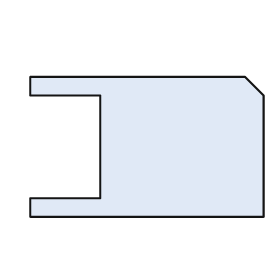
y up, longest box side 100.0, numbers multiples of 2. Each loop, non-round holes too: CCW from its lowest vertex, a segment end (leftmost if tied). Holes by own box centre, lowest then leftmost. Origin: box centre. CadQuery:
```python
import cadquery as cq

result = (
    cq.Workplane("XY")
    .moveTo(-50.0, -30.0)
    .lineTo(50.0, -30.0)
    .lineTo(50.0, 22.0)
    .lineTo(42.0, 30.0)
    .lineTo(-50.0, 30.0)
    .lineTo(-50.0, 22.0)
    .lineTo(-20.0, 22.0)
    .lineTo(-20.0, -22.0)
    .lineTo(-50.0, -22.0)
    .close()
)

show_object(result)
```